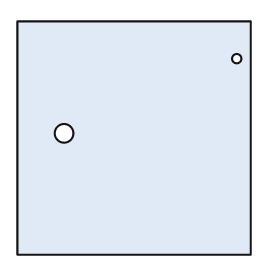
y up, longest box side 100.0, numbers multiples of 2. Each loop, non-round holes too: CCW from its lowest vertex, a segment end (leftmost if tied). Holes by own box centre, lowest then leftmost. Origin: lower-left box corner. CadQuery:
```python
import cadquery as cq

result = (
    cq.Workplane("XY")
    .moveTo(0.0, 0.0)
    .lineTo(100.0, 0.0)
    .lineTo(100.0, 100.0)
    .lineTo(0.0, 100.0)
    .close()
    .moveTo(20.0, 52.0)
    .circle(4.0)
    .moveTo(94.0, 84.0)
    .circle(2.0)
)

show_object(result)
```